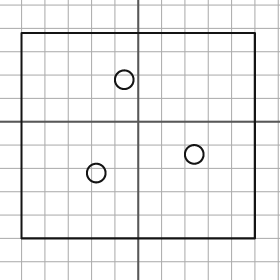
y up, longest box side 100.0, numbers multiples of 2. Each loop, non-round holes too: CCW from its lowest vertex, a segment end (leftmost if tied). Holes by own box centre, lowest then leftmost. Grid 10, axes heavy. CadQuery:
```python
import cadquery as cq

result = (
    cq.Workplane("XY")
    .moveTo(-50.0, -50.0)
    .lineTo(50.0, -50.0)
    .lineTo(50.0, 38.0)
    .lineTo(-50.0, 38.0)
    .close()
    .moveTo(-18.0, -22.0)
    .circle(4.0)
    .moveTo(24.0, -14.0)
    .circle(4.0)
    .moveTo(-6.0, 18.0)
    .circle(4.0)
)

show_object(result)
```